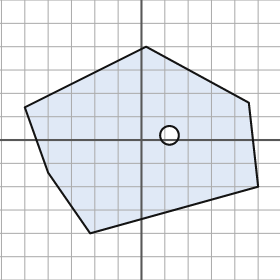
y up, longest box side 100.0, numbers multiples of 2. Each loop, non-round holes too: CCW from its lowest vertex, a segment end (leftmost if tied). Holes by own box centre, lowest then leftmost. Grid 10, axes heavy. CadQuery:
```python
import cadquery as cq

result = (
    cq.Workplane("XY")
    .moveTo(-22.0, -40.0)
    .lineTo(50.0, -20.0)
    .lineTo(46.0, 16.0)
    .lineTo(2.0, 40.0)
    .lineTo(-50.0, 14.0)
    .lineTo(-40.0, -14.0)
    .close()
    .moveTo(12.0, 2.0)
    .circle(4.0)
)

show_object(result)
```